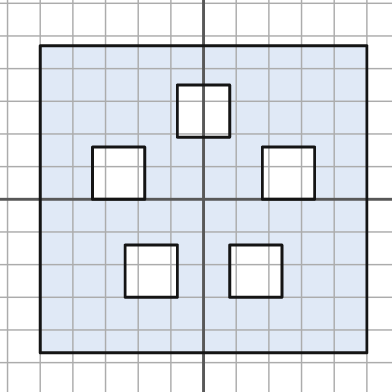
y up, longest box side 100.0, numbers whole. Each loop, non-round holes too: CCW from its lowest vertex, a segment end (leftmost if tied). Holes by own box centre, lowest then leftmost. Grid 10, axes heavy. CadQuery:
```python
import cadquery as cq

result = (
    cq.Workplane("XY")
    .moveTo(-50.0, -47.0)
    .lineTo(50.0, -47.0)
    .lineTo(50.0, 47.0)
    .lineTo(-50.0, 47.0)
    .close()
    .moveTo(-24.0, -30.0)
    .lineTo(-8.0, -30.0)
    .lineTo(-8.0, -14.0)
    .lineTo(-24.0, -14.0)
    .close()
    .moveTo(8.0, -30.0)
    .lineTo(24.0, -30.0)
    .lineTo(24.0, -14.0)
    .lineTo(8.0, -14.0)
    .close()
    .moveTo(-34.0, 0.0)
    .lineTo(-18.0, 0.0)
    .lineTo(-18.0, 16.0)
    .lineTo(-34.0, 16.0)
    .close()
    .moveTo(18.0, 0.0)
    .lineTo(34.0, 0.0)
    .lineTo(34.0, 16.0)
    .lineTo(18.0, 16.0)
    .close()
    .moveTo(-8.0, 19.0)
    .lineTo(8.0, 19.0)
    .lineTo(8.0, 35.0)
    .lineTo(-8.0, 35.0)
    .close()
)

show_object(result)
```